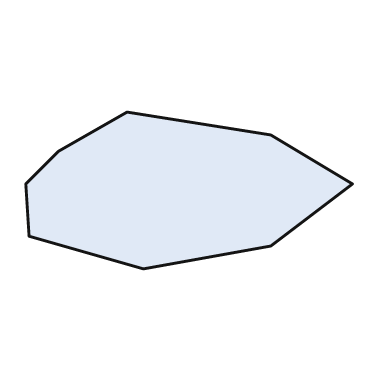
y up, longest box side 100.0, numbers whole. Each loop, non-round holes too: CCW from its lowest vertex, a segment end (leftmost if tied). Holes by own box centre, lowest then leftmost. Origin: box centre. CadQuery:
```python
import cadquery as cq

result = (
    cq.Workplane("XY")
    .moveTo(-14.0, -24.0)
    .lineTo(25.0, -17.0)
    .lineTo(50.0, 2.0)
    .lineTo(25.0, 17.0)
    .lineTo(-19.0, 24.0)
    .lineTo(-40.0, 12.0)
    .lineTo(-50.0, 2.0)
    .lineTo(-49.0, -14.0)
    .close()
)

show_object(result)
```